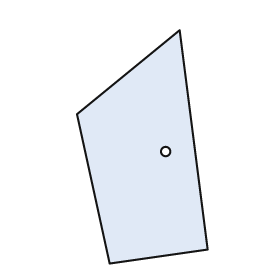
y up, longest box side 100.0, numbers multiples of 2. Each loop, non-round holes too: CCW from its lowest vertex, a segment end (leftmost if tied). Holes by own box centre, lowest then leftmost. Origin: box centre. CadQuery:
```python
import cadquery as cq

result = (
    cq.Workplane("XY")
    .moveTo(-14.0, -50.0)
    .lineTo(28.0, -44.0)
    .lineTo(16.0, 50.0)
    .lineTo(-28.0, 14.0)
    .close()
    .moveTo(10.0, -2.0)
    .circle(2.0)
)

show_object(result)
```